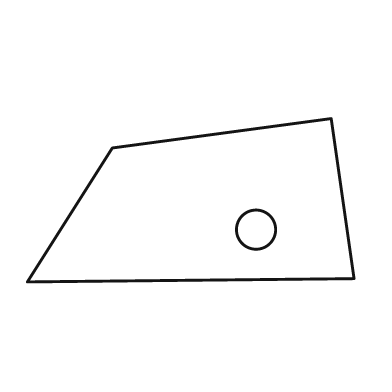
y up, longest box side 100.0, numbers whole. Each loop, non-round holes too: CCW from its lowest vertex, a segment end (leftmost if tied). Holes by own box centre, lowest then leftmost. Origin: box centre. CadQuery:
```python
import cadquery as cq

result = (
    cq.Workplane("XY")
    .moveTo(-50.0, -25.0)
    .lineTo(50.0, -24.0)
    .lineTo(43.0, 25.0)
    .lineTo(-24.0, 16.0)
    .close()
    .moveTo(20.0, -9.0)
    .circle(6.0)
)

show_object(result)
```